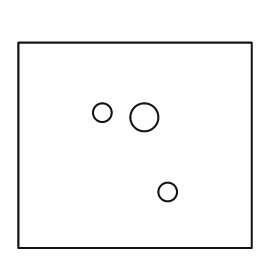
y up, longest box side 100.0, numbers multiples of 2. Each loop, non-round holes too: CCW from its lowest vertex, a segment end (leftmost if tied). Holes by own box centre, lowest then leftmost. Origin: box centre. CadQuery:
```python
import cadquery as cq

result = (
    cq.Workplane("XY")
    .moveTo(-50.0, -44.0)
    .lineTo(50.0, -44.0)
    .lineTo(50.0, 44.0)
    .lineTo(-50.0, 44.0)
    .close()
    .moveTo(14.0, -20.0)
    .circle(4.0)
    .moveTo(4.0, 12.0)
    .circle(6.0)
    .moveTo(-14.0, 14.0)
    .circle(4.0)
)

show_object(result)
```